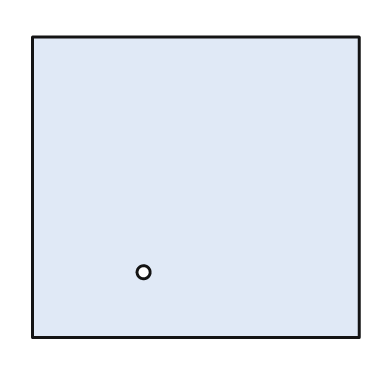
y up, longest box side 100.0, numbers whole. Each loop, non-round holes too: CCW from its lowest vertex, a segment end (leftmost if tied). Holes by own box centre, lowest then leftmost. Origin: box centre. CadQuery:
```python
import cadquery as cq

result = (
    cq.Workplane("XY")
    .moveTo(-50.0, -46.0)
    .lineTo(50.0, -46.0)
    .lineTo(50.0, 46.0)
    .lineTo(-50.0, 46.0)
    .close()
    .moveTo(-16.0, -26.0)
    .circle(2.0)
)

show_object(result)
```